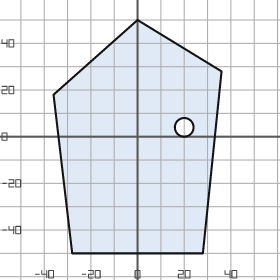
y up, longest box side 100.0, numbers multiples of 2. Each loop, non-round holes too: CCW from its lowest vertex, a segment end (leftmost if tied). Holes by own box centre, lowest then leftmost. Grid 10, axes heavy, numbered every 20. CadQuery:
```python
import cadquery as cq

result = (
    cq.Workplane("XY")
    .moveTo(-28.0, -50.0)
    .lineTo(28.0, -50.0)
    .lineTo(36.0, 28.0)
    .lineTo(0.0, 50.0)
    .lineTo(-36.0, 18.0)
    .close()
    .moveTo(20.0, 4.0)
    .circle(4.0)
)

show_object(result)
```